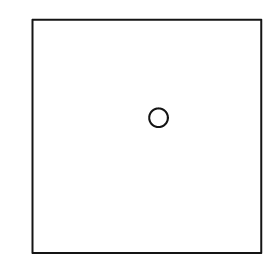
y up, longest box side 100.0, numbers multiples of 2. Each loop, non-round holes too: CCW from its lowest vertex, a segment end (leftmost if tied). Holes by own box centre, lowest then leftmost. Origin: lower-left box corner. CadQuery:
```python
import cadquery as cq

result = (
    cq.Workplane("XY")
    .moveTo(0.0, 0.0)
    .lineTo(98.0, 0.0)
    .lineTo(98.0, 100.0)
    .lineTo(0.0, 100.0)
    .close()
    .moveTo(54.0, 58.0)
    .circle(4.0)
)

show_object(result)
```